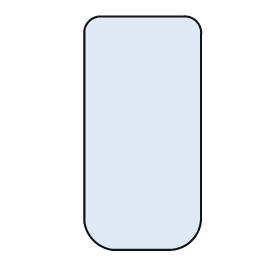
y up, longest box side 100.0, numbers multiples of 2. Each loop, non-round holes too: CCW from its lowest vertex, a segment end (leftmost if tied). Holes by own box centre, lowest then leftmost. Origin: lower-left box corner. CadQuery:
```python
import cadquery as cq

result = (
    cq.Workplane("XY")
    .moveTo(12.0, 0.0)
    .lineTo(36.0, 0.0)
    .threePointArc((46.0, 4.0), (50.0, 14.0))
    .lineTo(50.0, 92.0)
    .threePointArc((48.0, 98.0), (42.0, 100.0))
    .lineTo(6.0, 100.0)
    .threePointArc((2.0, 98.0), (0.0, 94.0))
    .lineTo(0.0, 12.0)
    .threePointArc((4.0, 4.0), (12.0, 0.0))
    .close()
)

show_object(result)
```